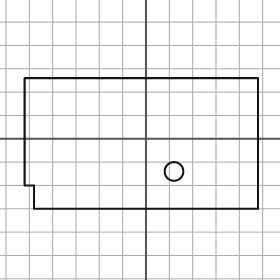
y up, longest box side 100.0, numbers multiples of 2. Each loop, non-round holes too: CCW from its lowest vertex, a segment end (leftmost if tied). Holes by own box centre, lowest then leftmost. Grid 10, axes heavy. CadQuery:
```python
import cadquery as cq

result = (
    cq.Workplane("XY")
    .moveTo(-48.0, -30.0)
    .lineTo(48.0, -30.0)
    .lineTo(48.0, 26.0)
    .lineTo(-52.0, 26.0)
    .lineTo(-52.0, -20.0)
    .lineTo(-48.0, -20.0)
    .close()
    .moveTo(12.0, -14.0)
    .circle(4.0)
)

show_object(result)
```